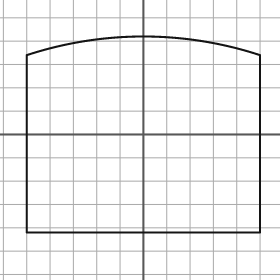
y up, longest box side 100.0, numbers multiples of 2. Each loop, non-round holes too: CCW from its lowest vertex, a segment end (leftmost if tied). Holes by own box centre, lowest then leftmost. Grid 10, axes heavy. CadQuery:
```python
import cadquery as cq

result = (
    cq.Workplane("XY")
    .moveTo(-50.0, -42.0)
    .lineTo(50.0, -42.0)
    .lineTo(50.0, 34.0)
    .threePointArc((0.0, 42.0), (-50.0, 34.0))
    .close()
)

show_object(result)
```